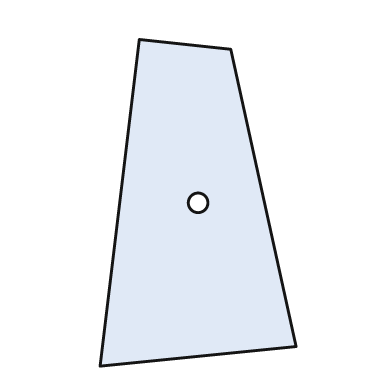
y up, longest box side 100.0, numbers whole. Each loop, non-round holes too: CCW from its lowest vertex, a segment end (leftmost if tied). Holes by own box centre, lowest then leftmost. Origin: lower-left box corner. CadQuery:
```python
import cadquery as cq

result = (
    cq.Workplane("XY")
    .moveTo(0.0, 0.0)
    .lineTo(60.0, 6.0)
    .lineTo(40.0, 97.0)
    .lineTo(12.0, 100.0)
    .close()
    .moveTo(30.0, 50.0)
    .circle(3.0)
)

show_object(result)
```